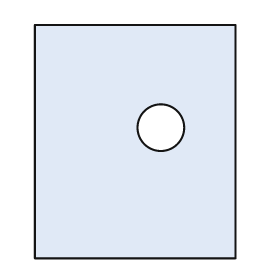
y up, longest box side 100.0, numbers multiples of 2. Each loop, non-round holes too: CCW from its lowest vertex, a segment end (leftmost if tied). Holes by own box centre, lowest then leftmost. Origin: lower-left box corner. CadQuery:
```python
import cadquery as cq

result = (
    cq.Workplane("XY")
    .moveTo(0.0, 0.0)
    .lineTo(86.0, 0.0)
    .lineTo(86.0, 100.0)
    .lineTo(0.0, 100.0)
    .close()
    .moveTo(54.0, 56.0)
    .circle(10.0)
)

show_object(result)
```